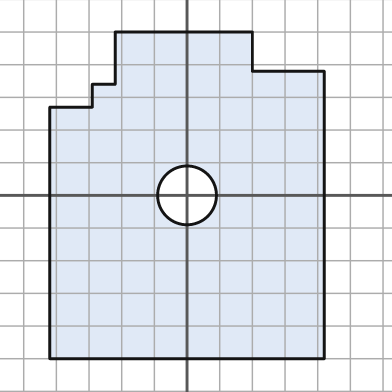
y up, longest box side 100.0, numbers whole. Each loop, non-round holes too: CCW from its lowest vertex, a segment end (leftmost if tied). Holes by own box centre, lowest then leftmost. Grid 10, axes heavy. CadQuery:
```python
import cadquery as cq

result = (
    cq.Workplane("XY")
    .moveTo(-42.0, -50.0)
    .lineTo(42.0, -50.0)
    .lineTo(42.0, 38.0)
    .lineTo(20.0, 38.0)
    .lineTo(20.0, 50.0)
    .lineTo(-22.0, 50.0)
    .lineTo(-22.0, 34.0)
    .lineTo(-29.0, 34.0)
    .lineTo(-29.0, 27.0)
    .lineTo(-42.0, 27.0)
    .close()
    .moveTo(0.0, 0.0)
    .circle(9.0)
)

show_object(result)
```